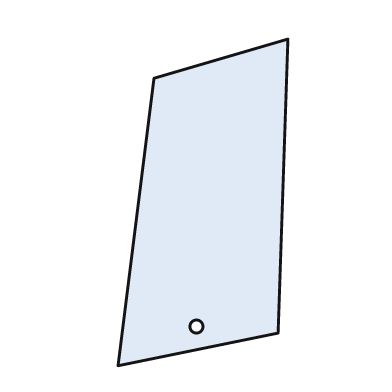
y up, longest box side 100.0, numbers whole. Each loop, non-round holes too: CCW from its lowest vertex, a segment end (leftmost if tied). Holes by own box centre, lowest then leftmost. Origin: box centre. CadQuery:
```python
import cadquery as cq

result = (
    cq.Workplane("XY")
    .moveTo(-26.0, -50.0)
    .lineTo(23.0, -40.0)
    .lineTo(26.0, 50.0)
    .lineTo(-15.0, 38.0)
    .close()
    .moveTo(-2.0, -38.0)
    .circle(2.0)
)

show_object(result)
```